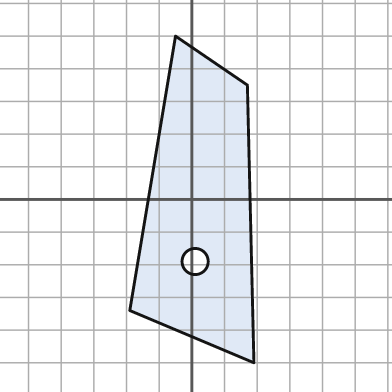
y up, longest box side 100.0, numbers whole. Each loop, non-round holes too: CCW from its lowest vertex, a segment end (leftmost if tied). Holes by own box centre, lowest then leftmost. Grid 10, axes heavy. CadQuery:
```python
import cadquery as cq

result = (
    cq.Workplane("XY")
    .moveTo(19.0, -50.0)
    .lineTo(17.0, 35.0)
    .lineTo(-5.0, 50.0)
    .lineTo(-19.0, -34.0)
    .close()
    .moveTo(1.0, -19.0)
    .circle(4.0)
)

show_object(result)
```